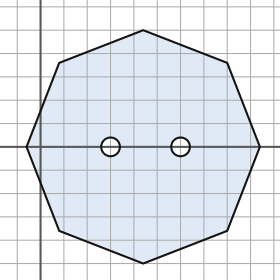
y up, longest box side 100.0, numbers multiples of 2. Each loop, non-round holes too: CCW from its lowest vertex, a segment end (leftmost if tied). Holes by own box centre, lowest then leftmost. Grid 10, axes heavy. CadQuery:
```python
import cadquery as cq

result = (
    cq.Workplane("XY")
    .moveTo(44.0, -50.0)
    .lineTo(80.0, -36.0)
    .lineTo(94.0, 0.0)
    .lineTo(80.0, 36.0)
    .lineTo(44.0, 50.0)
    .lineTo(8.0, 36.0)
    .lineTo(-6.0, 0.0)
    .lineTo(8.0, -36.0)
    .close()
    .moveTo(30.0, 0.0)
    .circle(4.0)
    .moveTo(60.0, 0.0)
    .circle(4.0)
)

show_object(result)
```